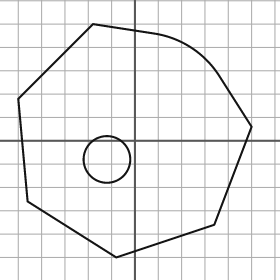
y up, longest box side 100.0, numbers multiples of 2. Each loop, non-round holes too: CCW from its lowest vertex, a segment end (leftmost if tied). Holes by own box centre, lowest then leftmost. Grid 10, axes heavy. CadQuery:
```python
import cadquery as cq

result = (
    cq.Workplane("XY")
    .moveTo(-8.0, -50.0)
    .lineTo(34.0, -36.0)
    .lineTo(50.0, 6.0)
    .lineTo(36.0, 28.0)
    .threePointArc((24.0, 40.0), (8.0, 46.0))
    .lineTo(-18.0, 50.0)
    .lineTo(-50.0, 18.0)
    .lineTo(-46.0, -26.0)
    .close()
    .moveTo(-12.0, -8.0)
    .circle(10.0)
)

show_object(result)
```